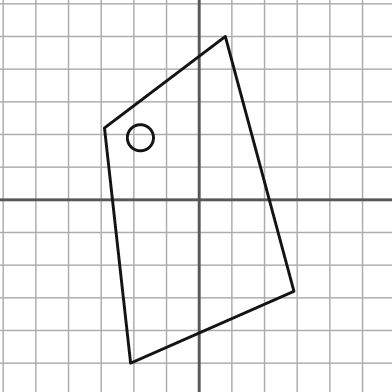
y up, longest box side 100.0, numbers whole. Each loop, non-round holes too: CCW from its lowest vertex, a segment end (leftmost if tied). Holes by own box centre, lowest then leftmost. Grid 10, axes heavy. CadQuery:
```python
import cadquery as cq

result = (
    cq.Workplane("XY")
    .moveTo(-21.0, -50.0)
    .lineTo(29.0, -28.0)
    .lineTo(8.0, 50.0)
    .lineTo(-29.0, 22.0)
    .close()
    .moveTo(-18.0, 19.0)
    .circle(4.0)
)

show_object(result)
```